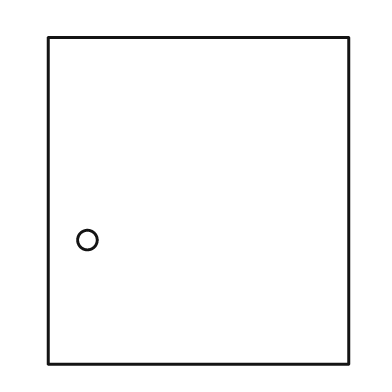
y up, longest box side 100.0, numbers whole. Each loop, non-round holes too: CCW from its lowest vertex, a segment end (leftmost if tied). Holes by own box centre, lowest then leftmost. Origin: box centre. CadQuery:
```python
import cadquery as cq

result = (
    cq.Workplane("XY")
    .moveTo(-46.0, -50.0)
    .lineTo(46.0, -50.0)
    .lineTo(46.0, 50.0)
    .lineTo(-46.0, 50.0)
    .close()
    .moveTo(-34.0, -12.0)
    .circle(3.0)
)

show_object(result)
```